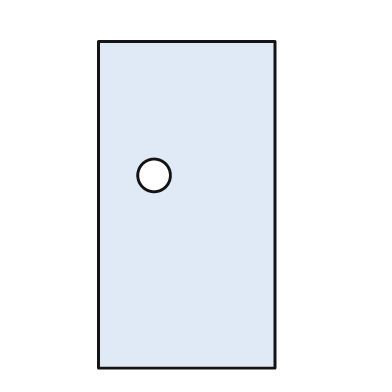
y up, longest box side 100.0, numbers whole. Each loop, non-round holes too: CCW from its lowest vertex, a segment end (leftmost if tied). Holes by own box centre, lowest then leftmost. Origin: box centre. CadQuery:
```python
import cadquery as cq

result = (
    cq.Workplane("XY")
    .moveTo(-27.0, -50.0)
    .lineTo(27.0, -50.0)
    .lineTo(27.0, 50.0)
    .lineTo(-27.0, 50.0)
    .close()
    .moveTo(-10.0, 9.0)
    .circle(5.0)
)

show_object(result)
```